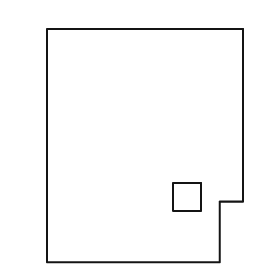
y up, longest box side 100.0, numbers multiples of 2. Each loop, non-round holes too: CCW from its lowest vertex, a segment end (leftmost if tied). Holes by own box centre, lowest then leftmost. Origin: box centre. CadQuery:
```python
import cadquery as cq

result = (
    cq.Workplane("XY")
    .moveTo(-42.0, -50.0)
    .lineTo(32.0, -50.0)
    .lineTo(32.0, -24.0)
    .lineTo(42.0, -24.0)
    .lineTo(42.0, 50.0)
    .lineTo(-42.0, 50.0)
    .close()
    .moveTo(12.0, -28.0)
    .lineTo(24.0, -28.0)
    .lineTo(24.0, -16.0)
    .lineTo(12.0, -16.0)
    .close()
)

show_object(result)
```